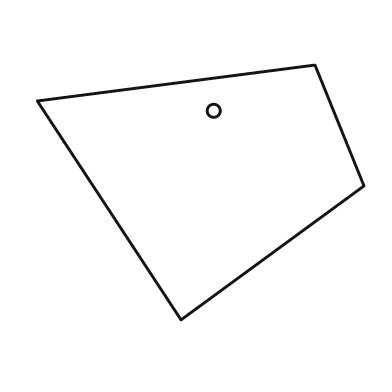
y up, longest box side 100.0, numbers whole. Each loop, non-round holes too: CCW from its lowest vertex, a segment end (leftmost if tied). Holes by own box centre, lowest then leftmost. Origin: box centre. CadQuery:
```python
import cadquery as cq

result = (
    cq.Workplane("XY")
    .moveTo(-6.0, -39.0)
    .lineTo(50.0, 2.0)
    .lineTo(35.0, 39.0)
    .lineTo(-50.0, 28.0)
    .close()
    .moveTo(4.0, 25.0)
    .circle(2.0)
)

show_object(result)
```